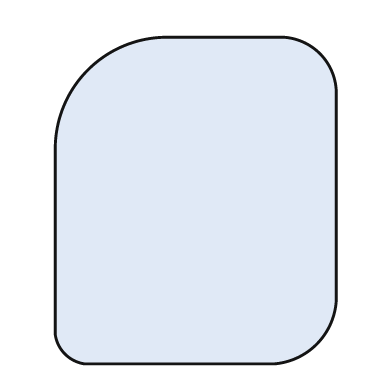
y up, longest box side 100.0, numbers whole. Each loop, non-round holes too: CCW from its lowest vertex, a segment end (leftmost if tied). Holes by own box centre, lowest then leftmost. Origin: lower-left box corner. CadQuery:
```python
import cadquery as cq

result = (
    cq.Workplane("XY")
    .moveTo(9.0, 0.0)
    .lineTo(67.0, 0.0)
    .threePointArc((80.0, 6.0), (86.0, 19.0))
    .lineTo(86.0, 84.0)
    .threePointArc((81.0, 95.0), (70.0, 100.0))
    .lineTo(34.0, 100.0)
    .threePointArc((10.0, 90.0), (0.0, 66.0))
    .lineTo(0.0, 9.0)
    .threePointArc((3.0, 3.0), (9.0, 0.0))
    .close()
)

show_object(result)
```